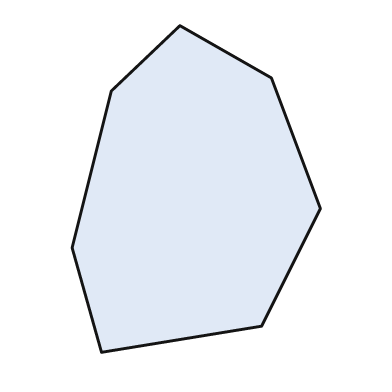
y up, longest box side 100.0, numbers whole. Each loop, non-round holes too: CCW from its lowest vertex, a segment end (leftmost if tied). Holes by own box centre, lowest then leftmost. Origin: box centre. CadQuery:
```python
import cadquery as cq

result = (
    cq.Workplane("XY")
    .moveTo(-29.0, -50.0)
    .lineTo(20.0, -42.0)
    .lineTo(38.0, -6.0)
    .lineTo(23.0, 34.0)
    .lineTo(-5.0, 50.0)
    .lineTo(-26.0, 30.0)
    .lineTo(-38.0, -18.0)
    .close()
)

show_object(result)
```